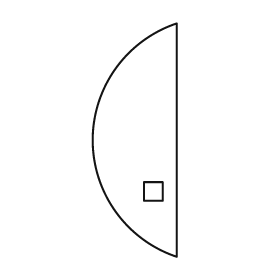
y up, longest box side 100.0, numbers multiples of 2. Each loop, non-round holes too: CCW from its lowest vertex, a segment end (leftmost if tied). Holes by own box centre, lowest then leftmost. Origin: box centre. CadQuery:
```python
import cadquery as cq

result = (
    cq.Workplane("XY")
    .moveTo(18.0, -50.0)
    .lineTo(18.0, 50.0)
    .threePointArc((-18.0, 0.0), (18.0, -50.0))
    .close()
    .moveTo(4.0, -26.0)
    .lineTo(12.0, -26.0)
    .lineTo(12.0, -18.0)
    .lineTo(4.0, -18.0)
    .close()
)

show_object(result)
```